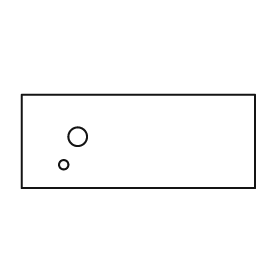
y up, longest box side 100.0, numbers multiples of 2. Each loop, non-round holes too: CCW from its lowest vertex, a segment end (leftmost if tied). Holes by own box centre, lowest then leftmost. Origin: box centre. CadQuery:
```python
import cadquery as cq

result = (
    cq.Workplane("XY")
    .moveTo(-50.0, -20.0)
    .lineTo(50.0, -20.0)
    .lineTo(50.0, 20.0)
    .lineTo(-50.0, 20.0)
    .close()
    .moveTo(-32.0, -10.0)
    .circle(2.0)
    .moveTo(-26.0, 2.0)
    .circle(4.0)
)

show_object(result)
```